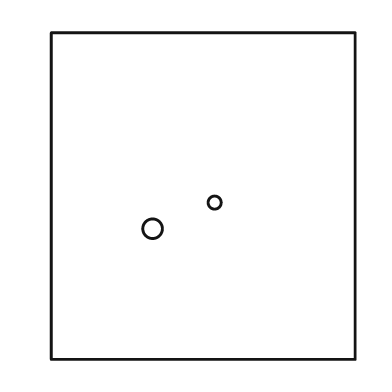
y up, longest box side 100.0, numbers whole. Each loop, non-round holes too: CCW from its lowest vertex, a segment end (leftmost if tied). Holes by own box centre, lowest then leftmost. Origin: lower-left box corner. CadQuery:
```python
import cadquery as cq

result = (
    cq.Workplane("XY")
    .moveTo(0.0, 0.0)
    .lineTo(93.0, 0.0)
    .lineTo(93.0, 100.0)
    .lineTo(0.0, 100.0)
    .close()
    .moveTo(31.0, 40.0)
    .circle(3.0)
    .moveTo(50.0, 48.0)
    .circle(2.0)
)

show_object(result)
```